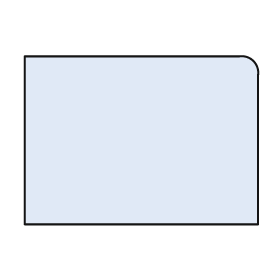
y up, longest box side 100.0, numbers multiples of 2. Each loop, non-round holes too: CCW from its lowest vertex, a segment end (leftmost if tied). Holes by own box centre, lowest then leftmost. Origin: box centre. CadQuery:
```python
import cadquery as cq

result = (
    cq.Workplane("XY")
    .moveTo(-50.0, -36.0)
    .lineTo(50.0, -36.0)
    .lineTo(50.0, 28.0)
    .threePointArc((48.0, 34.0), (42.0, 36.0))
    .lineTo(-50.0, 36.0)
    .close()
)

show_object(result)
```